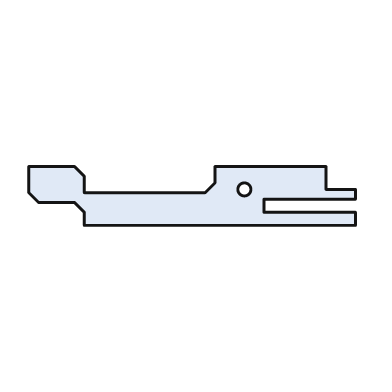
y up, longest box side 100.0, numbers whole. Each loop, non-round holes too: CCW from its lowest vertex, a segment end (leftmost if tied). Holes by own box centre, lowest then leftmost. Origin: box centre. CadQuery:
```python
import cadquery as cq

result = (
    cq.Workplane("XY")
    .moveTo(-33.0, -9.0)
    .lineTo(50.0, -9.0)
    .lineTo(50.0, -5.0)
    .lineTo(22.0, -5.0)
    .lineTo(22.0, -1.0)
    .lineTo(50.0, -1.0)
    .lineTo(50.0, 2.0)
    .lineTo(41.0, 2.0)
    .lineTo(41.0, 9.0)
    .lineTo(7.0, 9.0)
    .lineTo(7.0, 4.0)
    .lineTo(4.0, 1.0)
    .lineTo(-33.0, 1.0)
    .lineTo(-33.0, 6.0)
    .lineTo(-36.0, 9.0)
    .lineTo(-50.0, 9.0)
    .lineTo(-50.0, 1.0)
    .lineTo(-47.0, -2.0)
    .lineTo(-36.0, -2.0)
    .lineTo(-33.0, -5.0)
    .close()
    .moveTo(16.0, 2.0)
    .circle(2.0)
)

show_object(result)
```